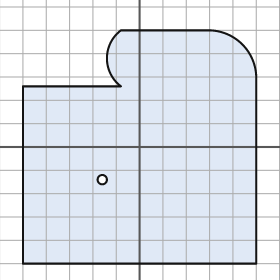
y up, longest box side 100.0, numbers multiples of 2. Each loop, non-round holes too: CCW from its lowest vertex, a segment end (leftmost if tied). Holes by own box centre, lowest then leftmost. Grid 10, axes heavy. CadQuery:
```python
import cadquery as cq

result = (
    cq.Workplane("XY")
    .moveTo(-50.0, -50.0)
    .lineTo(50.0, -50.0)
    .lineTo(50.0, 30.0)
    .threePointArc((44.0, 44.0), (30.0, 50.0))
    .lineTo(-8.0, 50.0)
    .threePointArc((-14.0, 38.0), (-8.0, 26.0))
    .lineTo(-50.0, 26.0)
    .close()
    .moveTo(-16.0, -14.0)
    .circle(2.0)
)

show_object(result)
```